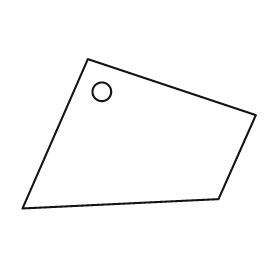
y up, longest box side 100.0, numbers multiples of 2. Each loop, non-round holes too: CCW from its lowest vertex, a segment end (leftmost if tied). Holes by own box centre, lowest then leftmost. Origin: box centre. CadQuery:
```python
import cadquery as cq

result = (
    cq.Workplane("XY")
    .moveTo(-50.0, -32.0)
    .lineTo(34.0, -28.0)
    .lineTo(50.0, 8.0)
    .lineTo(-22.0, 32.0)
    .close()
    .moveTo(-16.0, 18.0)
    .circle(4.0)
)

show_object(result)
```